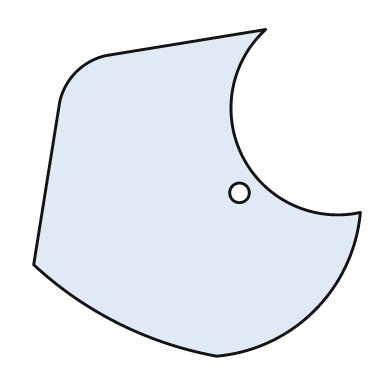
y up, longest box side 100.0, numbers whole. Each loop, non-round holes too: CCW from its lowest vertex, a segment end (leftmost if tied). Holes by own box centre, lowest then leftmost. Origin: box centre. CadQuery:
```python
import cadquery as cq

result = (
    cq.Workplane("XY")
    .moveTo(6.0, -50.0)
    .threePointArc((36.0, -36.0), (50.0, -6.0))
    .threePointArc((14.0, 11.0), (21.0, 50.0))
    .lineTo(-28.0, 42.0)
    .threePointArc((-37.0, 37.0), (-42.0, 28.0))
    .lineTo(-50.0, -22.0)
    .threePointArc((-24.0, -40.0), (6.0, -50.0))
    .close()
    .moveTo(13.0, 0.0)
    .circle(3.0)
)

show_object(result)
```